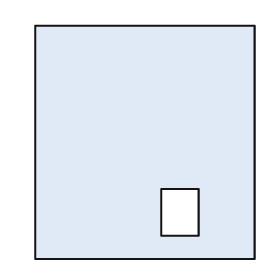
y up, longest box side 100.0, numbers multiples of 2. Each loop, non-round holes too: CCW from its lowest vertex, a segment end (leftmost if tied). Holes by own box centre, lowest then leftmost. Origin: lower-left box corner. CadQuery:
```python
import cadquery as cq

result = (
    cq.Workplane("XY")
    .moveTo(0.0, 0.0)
    .lineTo(94.0, 0.0)
    .lineTo(94.0, 100.0)
    .lineTo(0.0, 100.0)
    .close()
    .moveTo(54.0, 10.0)
    .lineTo(70.0, 10.0)
    .lineTo(70.0, 30.0)
    .lineTo(54.0, 30.0)
    .close()
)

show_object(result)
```